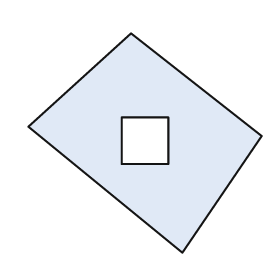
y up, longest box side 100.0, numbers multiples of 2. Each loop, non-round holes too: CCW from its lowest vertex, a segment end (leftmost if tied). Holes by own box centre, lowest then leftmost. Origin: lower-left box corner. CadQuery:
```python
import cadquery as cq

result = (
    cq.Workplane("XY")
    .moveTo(66.0, 0.0)
    .lineTo(100.0, 50.0)
    .lineTo(44.0, 94.0)
    .lineTo(0.0, 54.0)
    .close()
    .moveTo(40.0, 38.0)
    .lineTo(60.0, 38.0)
    .lineTo(60.0, 58.0)
    .lineTo(40.0, 58.0)
    .close()
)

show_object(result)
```